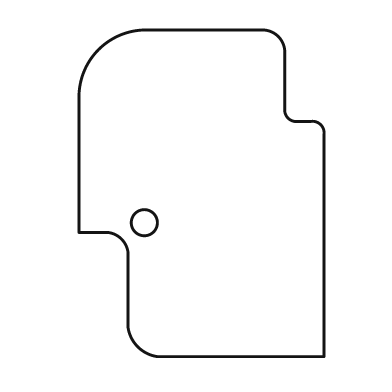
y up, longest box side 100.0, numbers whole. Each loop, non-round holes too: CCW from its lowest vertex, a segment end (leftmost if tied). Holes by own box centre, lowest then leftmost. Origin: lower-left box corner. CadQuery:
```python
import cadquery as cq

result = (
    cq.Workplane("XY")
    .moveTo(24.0, 0.0)
    .lineTo(75.0, 0.0)
    .lineTo(75.0, 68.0)
    .threePointArc((74.0, 71.0), (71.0, 72.0))
    .lineTo(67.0, 72.0)
    .threePointArc((64.0, 73.0), (63.0, 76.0))
    .lineTo(63.0, 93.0)
    .threePointArc((61.0, 98.0), (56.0, 100.0))
    .lineTo(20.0, 100.0)
    .threePointArc((6.0, 94.0), (0.0, 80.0))
    .lineTo(0.0, 38.0)
    .lineTo(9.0, 38.0)
    .threePointArc((13.0, 36.0), (15.0, 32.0))
    .lineTo(15.0, 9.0)
    .threePointArc((18.0, 3.0), (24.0, 0.0))
    .close()
    .moveTo(20.0, 41.0)
    .circle(4.0)
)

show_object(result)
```